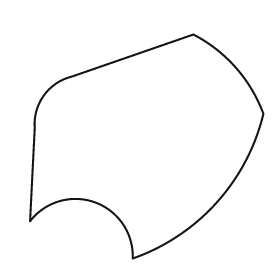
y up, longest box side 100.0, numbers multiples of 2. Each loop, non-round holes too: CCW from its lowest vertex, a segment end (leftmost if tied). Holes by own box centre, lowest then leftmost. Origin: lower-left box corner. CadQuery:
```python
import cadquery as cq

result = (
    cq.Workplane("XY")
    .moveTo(44.0, 0.0)
    .threePointArc((80.0, 24.0), (100.0, 62.0))
    .threePointArc((88.0, 82.0), (70.0, 96.0))
    .lineTo(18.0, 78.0)
    .threePointArc((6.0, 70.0), (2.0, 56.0))
    .lineTo(0.0, 16.0)
    .threePointArc((28.0, 24.0), (44.0, 0.0))
    .close()
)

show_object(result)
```